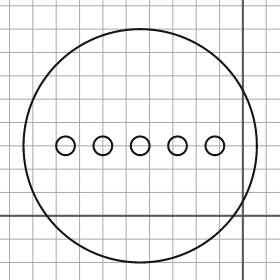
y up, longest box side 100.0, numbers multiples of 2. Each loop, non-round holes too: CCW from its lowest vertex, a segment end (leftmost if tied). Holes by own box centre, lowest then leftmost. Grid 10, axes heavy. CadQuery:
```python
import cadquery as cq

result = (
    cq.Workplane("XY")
    .moveTo(-44.0, 30.0)
    .circle(50.0)
    .moveTo(-76.0, 30.0)
    .circle(4.0)
    .moveTo(-60.0, 30.0)
    .circle(4.0)
    .moveTo(-44.0, 30.0)
    .circle(4.0)
    .moveTo(-28.0, 30.0)
    .circle(4.0)
    .moveTo(-12.0, 30.0)
    .circle(4.0)
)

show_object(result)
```